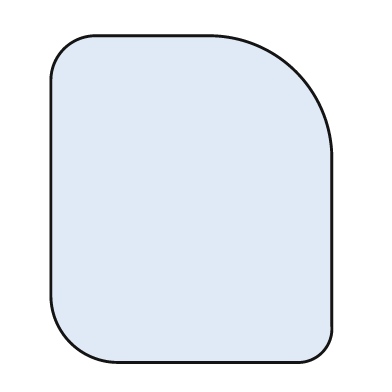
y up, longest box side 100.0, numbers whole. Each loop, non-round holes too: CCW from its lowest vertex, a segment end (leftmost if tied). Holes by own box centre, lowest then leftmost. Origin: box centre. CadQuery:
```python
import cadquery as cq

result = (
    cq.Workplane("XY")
    .moveTo(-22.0, -50.0)
    .lineTo(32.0, -50.0)
    .threePointArc((40.0, -47.0), (43.0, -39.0))
    .lineTo(43.0, 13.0)
    .threePointArc((32.0, 39.0), (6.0, 50.0))
    .lineTo(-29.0, 50.0)
    .threePointArc((-39.0, 46.0), (-43.0, 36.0))
    .lineTo(-43.0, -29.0)
    .threePointArc((-37.0, -44.0), (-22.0, -50.0))
    .close()
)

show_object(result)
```